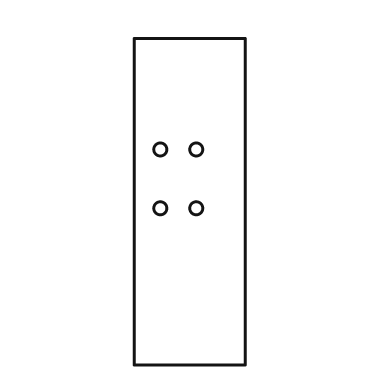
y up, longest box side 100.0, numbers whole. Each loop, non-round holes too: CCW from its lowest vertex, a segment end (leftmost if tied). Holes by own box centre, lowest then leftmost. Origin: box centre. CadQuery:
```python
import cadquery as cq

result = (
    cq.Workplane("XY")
    .moveTo(-17.0, -50.0)
    .lineTo(17.0, -50.0)
    .lineTo(17.0, 50.0)
    .lineTo(-17.0, 50.0)
    .close()
    .moveTo(-9.0, -2.0)
    .circle(2.0)
    .moveTo(2.0, -2.0)
    .circle(2.0)
    .moveTo(-9.0, 16.0)
    .circle(2.0)
    .moveTo(2.0, 16.0)
    .circle(2.0)
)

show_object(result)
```